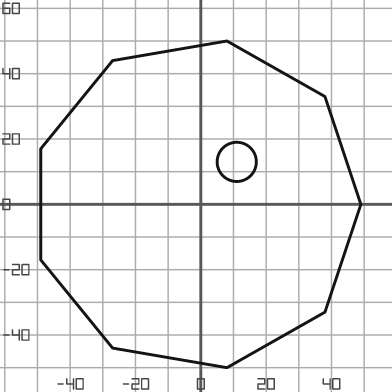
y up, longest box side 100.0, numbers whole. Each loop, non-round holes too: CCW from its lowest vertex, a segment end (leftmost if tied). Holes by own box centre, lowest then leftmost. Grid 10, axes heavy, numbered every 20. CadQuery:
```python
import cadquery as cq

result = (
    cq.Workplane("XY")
    .moveTo(8.0, -50.0)
    .lineTo(38.0, -33.0)
    .lineTo(49.0, 0.0)
    .lineTo(38.0, 33.0)
    .lineTo(8.0, 50.0)
    .lineTo(-27.0, 44.0)
    .lineTo(-49.0, 17.0)
    .lineTo(-49.0, -17.0)
    .lineTo(-27.0, -44.0)
    .close()
    .moveTo(11.0, 13.0)
    .circle(6.0)
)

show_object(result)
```